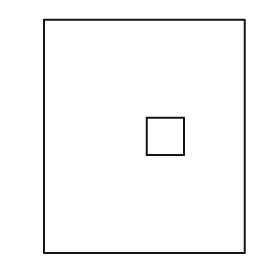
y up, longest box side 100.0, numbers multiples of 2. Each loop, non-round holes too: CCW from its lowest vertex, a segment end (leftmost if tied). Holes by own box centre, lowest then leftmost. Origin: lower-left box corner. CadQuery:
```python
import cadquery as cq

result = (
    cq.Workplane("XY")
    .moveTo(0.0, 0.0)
    .lineTo(86.0, 0.0)
    .lineTo(86.0, 100.0)
    .lineTo(0.0, 100.0)
    .close()
    .moveTo(44.0, 42.0)
    .lineTo(60.0, 42.0)
    .lineTo(60.0, 58.0)
    .lineTo(44.0, 58.0)
    .close()
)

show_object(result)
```